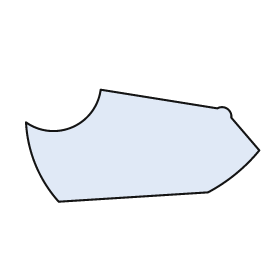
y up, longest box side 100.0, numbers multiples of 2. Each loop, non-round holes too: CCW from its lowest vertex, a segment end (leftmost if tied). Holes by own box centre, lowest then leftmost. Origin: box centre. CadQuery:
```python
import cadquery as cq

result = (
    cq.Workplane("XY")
    .moveTo(-36.0, -24.0)
    .lineTo(28.0, -20.0)
    .threePointArc((40.0, -12.0), (50.0, -2.0))
    .lineTo(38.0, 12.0)
    .threePointArc((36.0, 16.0), (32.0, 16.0))
    .lineTo(-18.0, 24.0)
    .threePointArc((-30.0, 8.0), (-50.0, 10.0))
    .threePointArc((-46.0, -8.0), (-36.0, -24.0))
    .close()
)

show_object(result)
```